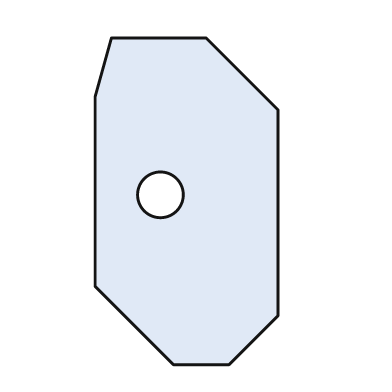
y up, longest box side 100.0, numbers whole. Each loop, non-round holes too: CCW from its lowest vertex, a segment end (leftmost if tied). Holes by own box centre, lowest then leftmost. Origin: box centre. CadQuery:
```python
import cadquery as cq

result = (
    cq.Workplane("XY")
    .moveTo(-4.0, -50.0)
    .lineTo(13.0, -50.0)
    .lineTo(28.0, -35.0)
    .lineTo(28.0, 28.0)
    .lineTo(6.0, 50.0)
    .lineTo(-23.0, 50.0)
    .lineTo(-28.0, 32.0)
    .lineTo(-28.0, -26.0)
    .close()
    .moveTo(-8.0, 2.0)
    .circle(7.0)
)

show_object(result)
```